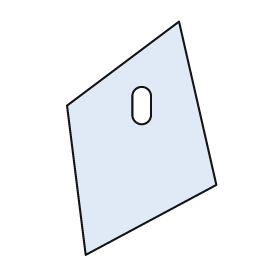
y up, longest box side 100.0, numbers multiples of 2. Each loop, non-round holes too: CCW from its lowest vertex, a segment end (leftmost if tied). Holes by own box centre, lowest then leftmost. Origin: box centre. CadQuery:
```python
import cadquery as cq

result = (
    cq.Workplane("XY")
    .moveTo(-24.0, -50.0)
    .lineTo(32.0, -20.0)
    .lineTo(16.0, 50.0)
    .lineTo(-32.0, 14.0)
    .close()
    .moveTo(-4.0, 10.0)
    .threePointArc((0.0, 6.0), (4.0, 10.0))
    .lineTo(4.0, 18.0)
    .threePointArc((0.0, 22.0), (-4.0, 18.0))
    .close()
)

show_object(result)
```